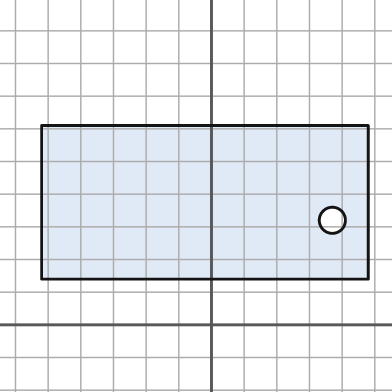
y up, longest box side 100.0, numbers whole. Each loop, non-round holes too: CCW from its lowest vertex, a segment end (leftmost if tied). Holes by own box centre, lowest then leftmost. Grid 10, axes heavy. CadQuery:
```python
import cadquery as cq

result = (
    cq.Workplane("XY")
    .moveTo(-52.0, 14.0)
    .lineTo(48.0, 14.0)
    .lineTo(48.0, 61.0)
    .lineTo(-52.0, 61.0)
    .close()
    .moveTo(37.0, 32.0)
    .circle(4.0)
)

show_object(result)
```